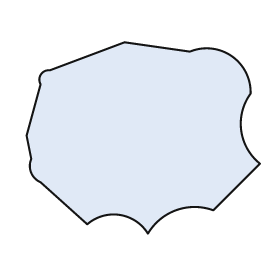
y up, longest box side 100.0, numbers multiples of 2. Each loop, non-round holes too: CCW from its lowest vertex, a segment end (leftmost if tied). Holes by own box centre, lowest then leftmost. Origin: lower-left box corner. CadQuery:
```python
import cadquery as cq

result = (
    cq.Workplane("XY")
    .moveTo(52.0, 0.0)
    .threePointArc((64.0, 10.0), (80.0, 10.0))
    .lineTo(100.0, 30.0)
    .threePointArc((92.0, 44.0), (96.0, 60.0))
    .threePointArc((88.0, 76.0), (70.0, 78.0))
    .lineTo(42.0, 82.0)
    .lineTo(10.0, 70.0)
    .threePointArc((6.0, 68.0), (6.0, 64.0))
    .lineTo(0.0, 42.0)
    .lineTo(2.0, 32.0)
    .threePointArc((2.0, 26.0), (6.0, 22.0))
    .lineTo(26.0, 4.0)
    .threePointArc((40.0, 8.0), (52.0, 0.0))
    .close()
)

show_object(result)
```